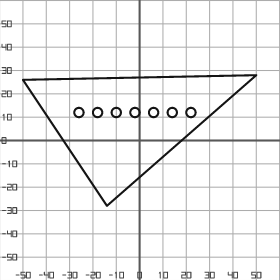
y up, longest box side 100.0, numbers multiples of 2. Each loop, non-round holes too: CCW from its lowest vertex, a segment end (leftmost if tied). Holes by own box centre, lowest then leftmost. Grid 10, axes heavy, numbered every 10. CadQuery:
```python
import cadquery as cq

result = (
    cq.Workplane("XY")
    .moveTo(-14.0, -28.0)
    .lineTo(50.0, 28.0)
    .lineTo(-50.0, 26.0)
    .close()
    .moveTo(-26.0, 12.0)
    .circle(2.0)
    .moveTo(-18.0, 12.0)
    .circle(2.0)
    .moveTo(-10.0, 12.0)
    .circle(2.0)
    .moveTo(-2.0, 12.0)
    .circle(2.0)
    .moveTo(6.0, 12.0)
    .circle(2.0)
    .moveTo(14.0, 12.0)
    .circle(2.0)
    .moveTo(22.0, 12.0)
    .circle(2.0)
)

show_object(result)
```